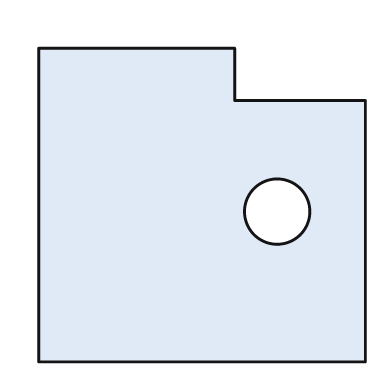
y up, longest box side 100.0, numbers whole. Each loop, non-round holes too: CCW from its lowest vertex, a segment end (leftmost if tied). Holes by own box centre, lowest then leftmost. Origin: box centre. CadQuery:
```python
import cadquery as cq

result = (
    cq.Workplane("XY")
    .moveTo(-50.0, -48.0)
    .lineTo(50.0, -48.0)
    .lineTo(50.0, 32.0)
    .lineTo(10.0, 32.0)
    .lineTo(10.0, 48.0)
    .lineTo(-50.0, 48.0)
    .close()
    .moveTo(23.0, -2.0)
    .circle(10.0)
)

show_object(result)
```